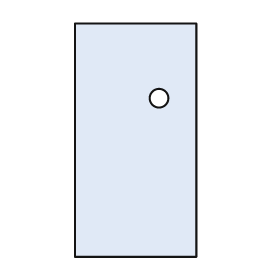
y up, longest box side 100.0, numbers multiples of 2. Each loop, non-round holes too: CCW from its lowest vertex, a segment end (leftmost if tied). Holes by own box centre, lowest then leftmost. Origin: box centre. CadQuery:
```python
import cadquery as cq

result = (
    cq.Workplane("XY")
    .moveTo(-26.0, -50.0)
    .lineTo(26.0, -50.0)
    .lineTo(26.0, 50.0)
    .lineTo(-26.0, 50.0)
    .close()
    .moveTo(10.0, 18.0)
    .circle(4.0)
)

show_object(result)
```